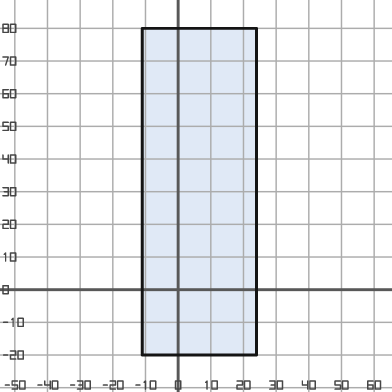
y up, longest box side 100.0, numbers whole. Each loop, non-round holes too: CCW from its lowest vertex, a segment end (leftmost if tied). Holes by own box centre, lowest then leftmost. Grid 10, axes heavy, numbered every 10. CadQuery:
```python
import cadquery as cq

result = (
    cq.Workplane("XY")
    .moveTo(-11.0, -20.0)
    .lineTo(24.0, -20.0)
    .lineTo(24.0, 80.0)
    .lineTo(-11.0, 80.0)
    .close()
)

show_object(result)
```